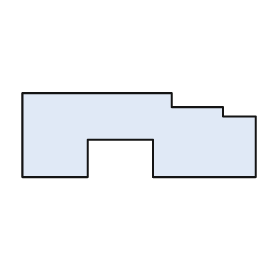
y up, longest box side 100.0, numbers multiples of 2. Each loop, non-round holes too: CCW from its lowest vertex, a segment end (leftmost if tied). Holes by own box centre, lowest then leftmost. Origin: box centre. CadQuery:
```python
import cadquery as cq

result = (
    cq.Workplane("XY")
    .moveTo(-50.0, -18.0)
    .lineTo(-22.0, -18.0)
    .lineTo(-22.0, -2.0)
    .lineTo(6.0, -2.0)
    .lineTo(6.0, -18.0)
    .lineTo(50.0, -18.0)
    .lineTo(50.0, 8.0)
    .lineTo(36.0, 8.0)
    .lineTo(36.0, 12.0)
    .lineTo(14.0, 12.0)
    .lineTo(14.0, 18.0)
    .lineTo(-50.0, 18.0)
    .close()
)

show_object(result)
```